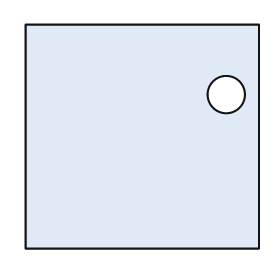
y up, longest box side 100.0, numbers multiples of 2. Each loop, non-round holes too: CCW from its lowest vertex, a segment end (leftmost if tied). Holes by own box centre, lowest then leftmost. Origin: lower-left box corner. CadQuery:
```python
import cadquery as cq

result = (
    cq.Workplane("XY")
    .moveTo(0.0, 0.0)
    .lineTo(100.0, 0.0)
    .lineTo(100.0, 96.0)
    .lineTo(0.0, 96.0)
    .close()
    .moveTo(86.0, 66.0)
    .circle(8.0)
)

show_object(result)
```